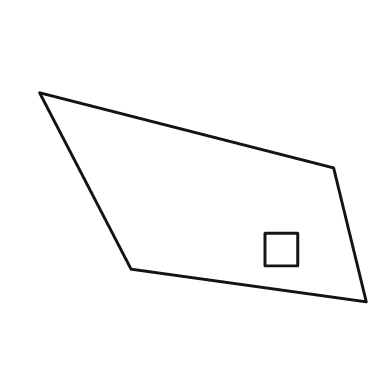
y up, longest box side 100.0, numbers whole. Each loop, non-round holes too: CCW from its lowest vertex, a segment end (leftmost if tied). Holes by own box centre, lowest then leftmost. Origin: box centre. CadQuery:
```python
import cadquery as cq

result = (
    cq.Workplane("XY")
    .moveTo(50.0, -32.0)
    .lineTo(40.0, 9.0)
    .lineTo(-50.0, 32.0)
    .lineTo(-22.0, -22.0)
    .close()
    .moveTo(19.0, -21.0)
    .lineTo(29.0, -21.0)
    .lineTo(29.0, -11.0)
    .lineTo(19.0, -11.0)
    .close()
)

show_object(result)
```